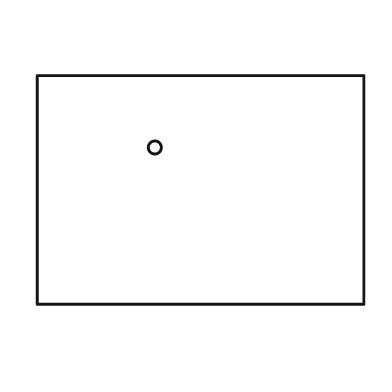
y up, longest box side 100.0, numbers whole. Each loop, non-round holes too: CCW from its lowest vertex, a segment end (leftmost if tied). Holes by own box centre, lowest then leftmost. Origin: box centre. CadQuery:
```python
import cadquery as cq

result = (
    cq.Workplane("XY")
    .moveTo(-50.0, -35.0)
    .lineTo(50.0, -35.0)
    .lineTo(50.0, 35.0)
    .lineTo(-50.0, 35.0)
    .close()
    .moveTo(-14.0, 13.0)
    .circle(2.0)
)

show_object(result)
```